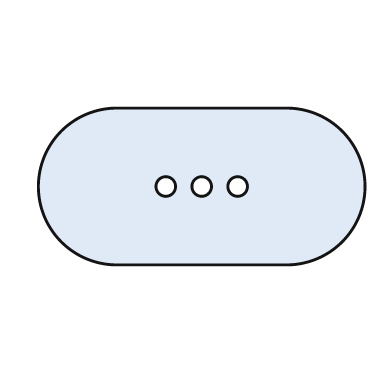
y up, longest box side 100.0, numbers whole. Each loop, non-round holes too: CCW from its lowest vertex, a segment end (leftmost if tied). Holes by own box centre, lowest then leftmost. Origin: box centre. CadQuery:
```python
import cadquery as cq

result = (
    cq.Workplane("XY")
    .moveTo(-26.0, -24.0)
    .lineTo(26.0, -24.0)
    .threePointArc((50.0, 0.0), (26.0, 24.0))
    .lineTo(-26.0, 24.0)
    .threePointArc((-50.0, 0.0), (-26.0, -24.0))
    .close()
    .moveTo(-11.0, 0.0)
    .circle(3.0)
    .moveTo(0.0, 0.0)
    .circle(3.0)
    .moveTo(11.0, 0.0)
    .circle(3.0)
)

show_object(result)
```